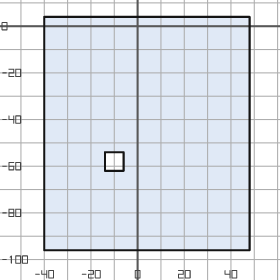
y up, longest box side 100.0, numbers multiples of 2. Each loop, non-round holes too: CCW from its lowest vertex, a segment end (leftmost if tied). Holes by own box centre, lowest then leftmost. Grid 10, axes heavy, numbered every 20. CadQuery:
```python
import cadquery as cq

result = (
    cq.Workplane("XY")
    .moveTo(-40.0, -96.0)
    .lineTo(48.0, -96.0)
    .lineTo(48.0, 4.0)
    .lineTo(-40.0, 4.0)
    .close()
    .moveTo(-14.0, -62.0)
    .lineTo(-6.0, -62.0)
    .lineTo(-6.0, -54.0)
    .lineTo(-14.0, -54.0)
    .close()
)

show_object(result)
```